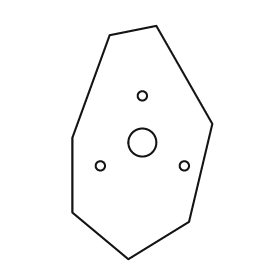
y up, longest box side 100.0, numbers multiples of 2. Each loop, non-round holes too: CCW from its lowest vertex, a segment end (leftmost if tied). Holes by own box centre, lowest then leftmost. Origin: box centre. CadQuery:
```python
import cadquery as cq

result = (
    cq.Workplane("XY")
    .moveTo(-6.0, -50.0)
    .lineTo(20.0, -34.0)
    .lineTo(30.0, 8.0)
    .lineTo(6.0, 50.0)
    .lineTo(-14.0, 46.0)
    .lineTo(-30.0, 2.0)
    .lineTo(-30.0, -30.0)
    .close()
    .moveTo(-18.0, -10.0)
    .circle(2.0)
    .moveTo(18.0, -10.0)
    .circle(2.0)
    .moveTo(0.0, 0.0)
    .circle(6.0)
    .moveTo(0.0, 20.0)
    .circle(2.0)
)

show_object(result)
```